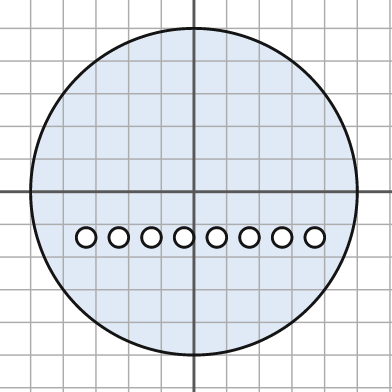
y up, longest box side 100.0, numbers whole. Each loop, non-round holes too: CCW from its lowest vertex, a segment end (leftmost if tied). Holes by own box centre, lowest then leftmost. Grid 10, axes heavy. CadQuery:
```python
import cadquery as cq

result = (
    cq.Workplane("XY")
    .moveTo(0.0, 0.0)
    .circle(50.0)
    .moveTo(-33.0, -14.0)
    .circle(3.0)
    .moveTo(-23.0, -14.0)
    .circle(3.0)
    .moveTo(-13.0, -14.0)
    .circle(3.0)
    .moveTo(-3.0, -14.0)
    .circle(3.0)
    .moveTo(7.0, -14.0)
    .circle(3.0)
    .moveTo(17.0, -14.0)
    .circle(3.0)
    .moveTo(27.0, -14.0)
    .circle(3.0)
    .moveTo(37.0, -14.0)
    .circle(3.0)
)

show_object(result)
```